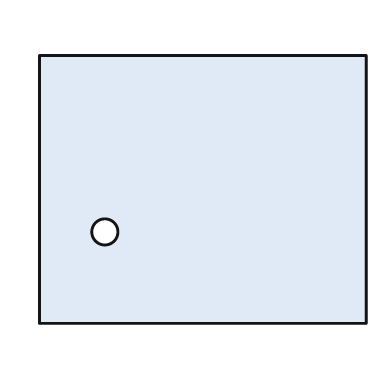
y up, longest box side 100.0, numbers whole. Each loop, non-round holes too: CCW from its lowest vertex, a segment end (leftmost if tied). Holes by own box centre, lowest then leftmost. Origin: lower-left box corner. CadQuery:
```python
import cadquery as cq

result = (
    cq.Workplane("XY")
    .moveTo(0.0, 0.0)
    .lineTo(100.0, 0.0)
    .lineTo(100.0, 82.0)
    .lineTo(0.0, 82.0)
    .close()
    .moveTo(20.0, 28.0)
    .circle(4.0)
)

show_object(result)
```